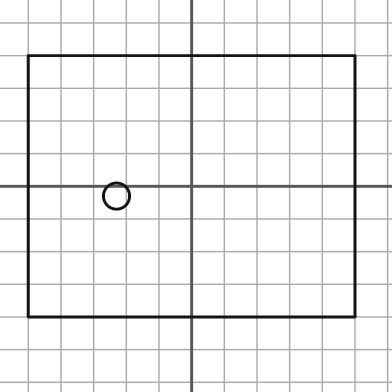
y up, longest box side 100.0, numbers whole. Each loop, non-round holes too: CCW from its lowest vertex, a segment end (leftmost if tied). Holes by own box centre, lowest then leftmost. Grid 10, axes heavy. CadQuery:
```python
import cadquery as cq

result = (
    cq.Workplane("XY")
    .moveTo(-50.0, -40.0)
    .lineTo(50.0, -40.0)
    .lineTo(50.0, 40.0)
    .lineTo(-50.0, 40.0)
    .close()
    .moveTo(-23.0, -3.0)
    .circle(4.0)
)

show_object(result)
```